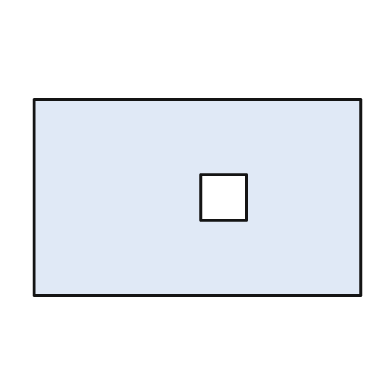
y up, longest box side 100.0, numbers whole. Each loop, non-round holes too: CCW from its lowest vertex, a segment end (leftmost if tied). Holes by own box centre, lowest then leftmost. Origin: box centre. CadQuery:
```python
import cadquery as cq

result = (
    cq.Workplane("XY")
    .moveTo(-50.0, -30.0)
    .lineTo(50.0, -30.0)
    .lineTo(50.0, 30.0)
    .lineTo(-50.0, 30.0)
    .close()
    .moveTo(1.0, -7.0)
    .lineTo(15.0, -7.0)
    .lineTo(15.0, 7.0)
    .lineTo(1.0, 7.0)
    .close()
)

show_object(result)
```